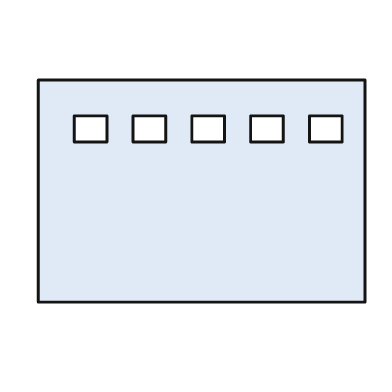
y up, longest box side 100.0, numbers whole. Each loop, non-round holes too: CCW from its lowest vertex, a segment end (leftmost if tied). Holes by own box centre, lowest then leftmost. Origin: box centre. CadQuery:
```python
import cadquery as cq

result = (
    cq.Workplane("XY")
    .moveTo(-50.0, -34.0)
    .lineTo(50.0, -34.0)
    .lineTo(50.0, 34.0)
    .lineTo(-50.0, 34.0)
    .close()
    .moveTo(-39.0, 15.0)
    .lineTo(-29.0, 15.0)
    .lineTo(-29.0, 23.0)
    .lineTo(-39.0, 23.0)
    .close()
    .moveTo(-21.0, 15.0)
    .lineTo(-11.0, 15.0)
    .lineTo(-11.0, 23.0)
    .lineTo(-21.0, 23.0)
    .close()
    .moveTo(-3.0, 15.0)
    .lineTo(7.0, 15.0)
    .lineTo(7.0, 23.0)
    .lineTo(-3.0, 23.0)
    .close()
    .moveTo(15.0, 15.0)
    .lineTo(25.0, 15.0)
    .lineTo(25.0, 23.0)
    .lineTo(15.0, 23.0)
    .close()
    .moveTo(33.0, 15.0)
    .lineTo(43.0, 15.0)
    .lineTo(43.0, 23.0)
    .lineTo(33.0, 23.0)
    .close()
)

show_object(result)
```